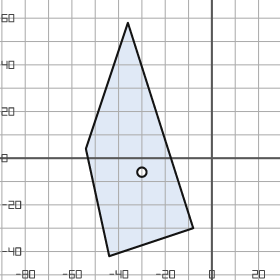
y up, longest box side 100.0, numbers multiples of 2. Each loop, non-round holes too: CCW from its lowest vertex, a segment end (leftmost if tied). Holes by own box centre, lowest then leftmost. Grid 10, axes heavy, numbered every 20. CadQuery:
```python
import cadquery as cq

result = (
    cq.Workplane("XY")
    .moveTo(-44.0, -42.0)
    .lineTo(-8.0, -30.0)
    .lineTo(-36.0, 58.0)
    .lineTo(-54.0, 4.0)
    .close()
    .moveTo(-30.0, -6.0)
    .circle(2.0)
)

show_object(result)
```